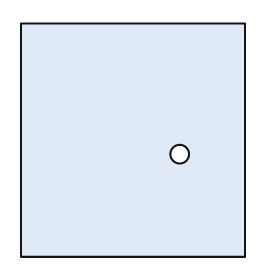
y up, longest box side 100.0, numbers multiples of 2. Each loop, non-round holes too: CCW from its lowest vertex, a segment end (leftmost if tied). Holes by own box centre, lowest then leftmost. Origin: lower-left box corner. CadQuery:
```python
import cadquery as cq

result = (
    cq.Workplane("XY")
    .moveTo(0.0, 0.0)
    .lineTo(96.0, 0.0)
    .lineTo(96.0, 100.0)
    .lineTo(0.0, 100.0)
    .close()
    .moveTo(68.0, 44.0)
    .circle(4.0)
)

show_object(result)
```